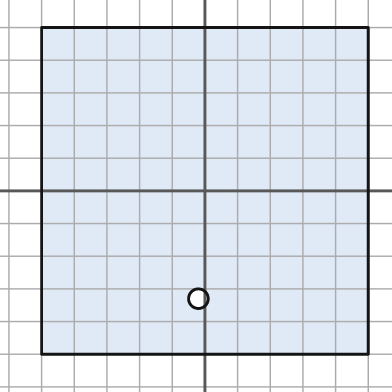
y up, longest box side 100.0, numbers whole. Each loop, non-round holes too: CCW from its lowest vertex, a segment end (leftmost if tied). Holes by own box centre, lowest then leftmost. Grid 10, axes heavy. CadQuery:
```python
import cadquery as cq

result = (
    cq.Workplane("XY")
    .moveTo(-50.0, -50.0)
    .lineTo(50.0, -50.0)
    .lineTo(50.0, 50.0)
    .lineTo(-50.0, 50.0)
    .close()
    .moveTo(-2.0, -33.0)
    .circle(3.0)
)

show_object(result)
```